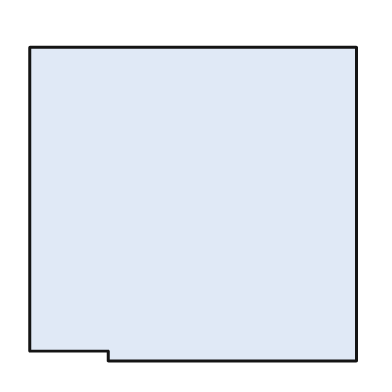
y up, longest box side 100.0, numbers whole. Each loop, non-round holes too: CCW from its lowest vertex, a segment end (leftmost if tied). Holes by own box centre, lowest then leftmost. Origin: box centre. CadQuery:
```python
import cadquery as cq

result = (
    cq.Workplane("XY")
    .moveTo(-26.0, -48.0)
    .lineTo(50.0, -48.0)
    .lineTo(50.0, 48.0)
    .lineTo(-50.0, 48.0)
    .lineTo(-50.0, -45.0)
    .lineTo(-26.0, -45.0)
    .close()
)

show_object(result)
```